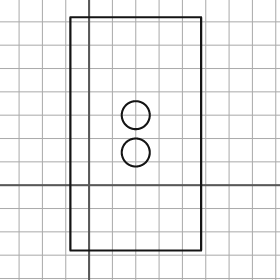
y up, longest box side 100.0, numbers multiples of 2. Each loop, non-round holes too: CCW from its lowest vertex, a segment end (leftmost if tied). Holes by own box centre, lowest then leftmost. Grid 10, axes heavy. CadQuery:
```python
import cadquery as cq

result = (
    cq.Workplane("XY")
    .moveTo(-8.0, -28.0)
    .lineTo(48.0, -28.0)
    .lineTo(48.0, 72.0)
    .lineTo(-8.0, 72.0)
    .close()
    .moveTo(20.0, 14.0)
    .circle(6.0)
    .moveTo(20.0, 30.0)
    .circle(6.0)
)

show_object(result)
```